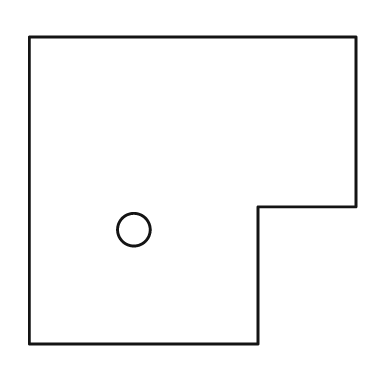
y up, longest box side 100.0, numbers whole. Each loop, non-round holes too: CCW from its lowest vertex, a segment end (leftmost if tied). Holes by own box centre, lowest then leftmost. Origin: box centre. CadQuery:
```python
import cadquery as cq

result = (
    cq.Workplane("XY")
    .moveTo(-50.0, -47.0)
    .lineTo(20.0, -47.0)
    .lineTo(20.0, -5.0)
    .lineTo(50.0, -5.0)
    .lineTo(50.0, 47.0)
    .lineTo(-50.0, 47.0)
    .close()
    .moveTo(-18.0, -12.0)
    .circle(5.0)
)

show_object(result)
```